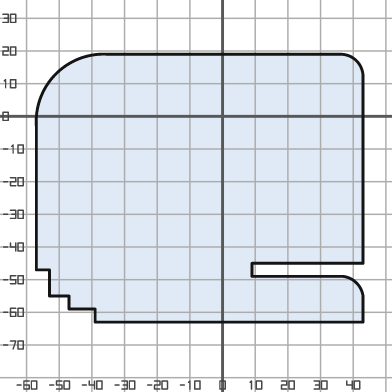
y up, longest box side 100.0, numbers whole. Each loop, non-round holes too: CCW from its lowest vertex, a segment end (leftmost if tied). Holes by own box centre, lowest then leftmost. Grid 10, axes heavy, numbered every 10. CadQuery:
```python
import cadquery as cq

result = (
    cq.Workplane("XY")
    .moveTo(-39.0, -63.0)
    .lineTo(43.0, -63.0)
    .lineTo(43.0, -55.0)
    .threePointArc((41.0, -51.0), (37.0, -49.0))
    .lineTo(9.0, -49.0)
    .lineTo(9.0, -45.0)
    .lineTo(43.0, -45.0)
    .lineTo(43.0, 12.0)
    .threePointArc((41.0, 17.0), (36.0, 19.0))
    .lineTo(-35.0, 19.0)
    .threePointArc((-51.0, 13.0), (-57.0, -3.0))
    .lineTo(-57.0, -47.0)
    .lineTo(-53.0, -47.0)
    .lineTo(-53.0, -55.0)
    .lineTo(-47.0, -55.0)
    .lineTo(-47.0, -59.0)
    .lineTo(-39.0, -59.0)
    .close()
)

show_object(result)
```